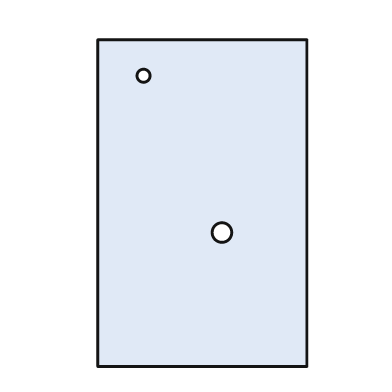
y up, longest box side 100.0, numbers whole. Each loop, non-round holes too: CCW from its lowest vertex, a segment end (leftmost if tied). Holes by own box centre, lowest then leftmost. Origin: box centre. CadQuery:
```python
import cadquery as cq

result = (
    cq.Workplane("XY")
    .moveTo(-32.0, -50.0)
    .lineTo(32.0, -50.0)
    .lineTo(32.0, 50.0)
    .lineTo(-32.0, 50.0)
    .close()
    .moveTo(6.0, -9.0)
    .circle(3.0)
    .moveTo(-18.0, 39.0)
    .circle(2.0)
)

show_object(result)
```